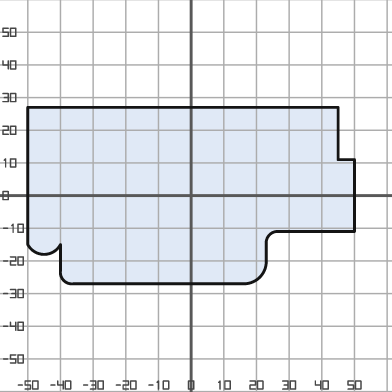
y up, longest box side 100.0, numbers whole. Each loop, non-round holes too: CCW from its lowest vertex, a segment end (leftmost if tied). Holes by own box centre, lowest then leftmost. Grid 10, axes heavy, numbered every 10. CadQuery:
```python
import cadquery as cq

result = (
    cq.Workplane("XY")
    .moveTo(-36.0, -27.0)
    .lineTo(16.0, -27.0)
    .threePointArc((21.0, -25.0), (23.0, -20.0))
    .lineTo(23.0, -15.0)
    .threePointArc((24.0, -12.0), (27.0, -11.0))
    .lineTo(50.0, -11.0)
    .lineTo(50.0, 11.0)
    .lineTo(45.0, 11.0)
    .lineTo(45.0, 27.0)
    .lineTo(-50.0, 27.0)
    .lineTo(-50.0, -15.0)
    .threePointArc((-45.0, -18.0), (-40.0, -15.0))
    .lineTo(-40.0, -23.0)
    .threePointArc((-39.0, -26.0), (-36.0, -27.0))
    .close()
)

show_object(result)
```